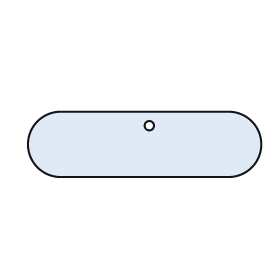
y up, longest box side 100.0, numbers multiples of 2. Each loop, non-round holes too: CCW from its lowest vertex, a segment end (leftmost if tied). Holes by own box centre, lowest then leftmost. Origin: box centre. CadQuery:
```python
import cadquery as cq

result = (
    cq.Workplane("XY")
    .moveTo(-36.0, -14.0)
    .lineTo(36.0, -14.0)
    .threePointArc((50.0, 0.0), (36.0, 14.0))
    .lineTo(-36.0, 14.0)
    .threePointArc((-50.0, 0.0), (-36.0, -14.0))
    .close()
    .moveTo(2.0, 8.0)
    .circle(2.0)
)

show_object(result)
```